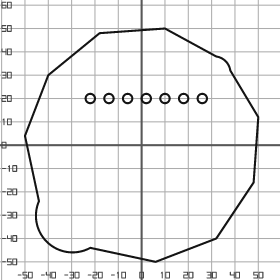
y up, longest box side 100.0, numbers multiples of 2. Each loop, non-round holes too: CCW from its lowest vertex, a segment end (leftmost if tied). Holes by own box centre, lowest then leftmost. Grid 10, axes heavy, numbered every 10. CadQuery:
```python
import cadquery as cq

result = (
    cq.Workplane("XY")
    .moveTo(6.0, -50.0)
    .lineTo(32.0, -40.0)
    .lineTo(48.0, -16.0)
    .lineTo(50.0, 12.0)
    .lineTo(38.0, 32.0)
    .threePointArc((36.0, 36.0), (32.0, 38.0))
    .lineTo(10.0, 50.0)
    .lineTo(-18.0, 48.0)
    .lineTo(-40.0, 30.0)
    .lineTo(-50.0, 4.0)
    .lineTo(-44.0, -24.0)
    .threePointArc((-40.0, -42.0), (-22.0, -44.0))
    .close()
    .moveTo(-22.0, 20.0)
    .circle(2.0)
    .moveTo(-14.0, 20.0)
    .circle(2.0)
    .moveTo(-6.0, 20.0)
    .circle(2.0)
    .moveTo(2.0, 20.0)
    .circle(2.0)
    .moveTo(10.0, 20.0)
    .circle(2.0)
    .moveTo(18.0, 20.0)
    .circle(2.0)
    .moveTo(26.0, 20.0)
    .circle(2.0)
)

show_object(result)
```